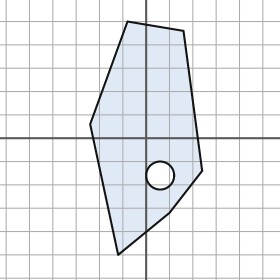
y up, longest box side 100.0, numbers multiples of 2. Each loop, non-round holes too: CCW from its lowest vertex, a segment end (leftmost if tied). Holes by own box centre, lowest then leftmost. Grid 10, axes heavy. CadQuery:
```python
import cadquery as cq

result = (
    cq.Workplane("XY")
    .moveTo(-12.0, -50.0)
    .lineTo(10.0, -32.0)
    .lineTo(24.0, -14.0)
    .lineTo(16.0, 46.0)
    .lineTo(-8.0, 50.0)
    .lineTo(-24.0, 6.0)
    .close()
    .moveTo(6.0, -16.0)
    .circle(6.0)
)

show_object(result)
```